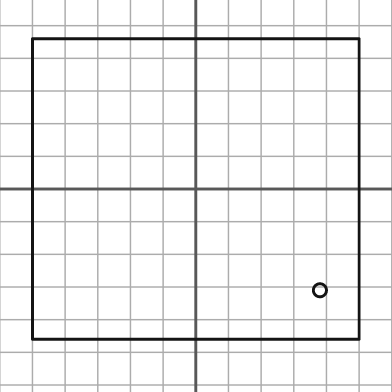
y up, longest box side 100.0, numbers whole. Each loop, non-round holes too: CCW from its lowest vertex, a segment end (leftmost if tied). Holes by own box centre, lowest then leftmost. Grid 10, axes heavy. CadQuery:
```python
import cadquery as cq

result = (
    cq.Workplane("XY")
    .moveTo(-50.0, -46.0)
    .lineTo(50.0, -46.0)
    .lineTo(50.0, 46.0)
    .lineTo(-50.0, 46.0)
    .close()
    .moveTo(38.0, -31.0)
    .circle(2.0)
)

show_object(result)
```